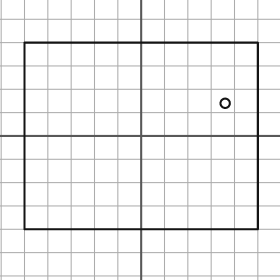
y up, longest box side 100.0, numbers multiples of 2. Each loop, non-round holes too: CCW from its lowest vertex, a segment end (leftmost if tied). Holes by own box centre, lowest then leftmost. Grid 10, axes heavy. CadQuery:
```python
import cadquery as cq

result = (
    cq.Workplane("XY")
    .moveTo(-50.0, -40.0)
    .lineTo(50.0, -40.0)
    .lineTo(50.0, 40.0)
    .lineTo(-50.0, 40.0)
    .close()
    .moveTo(36.0, 14.0)
    .circle(2.0)
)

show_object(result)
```